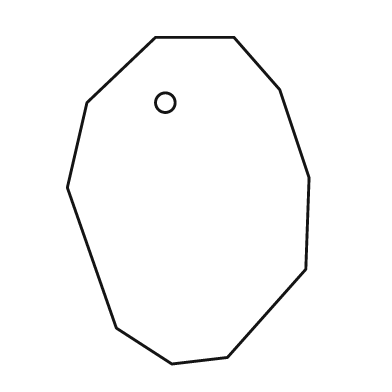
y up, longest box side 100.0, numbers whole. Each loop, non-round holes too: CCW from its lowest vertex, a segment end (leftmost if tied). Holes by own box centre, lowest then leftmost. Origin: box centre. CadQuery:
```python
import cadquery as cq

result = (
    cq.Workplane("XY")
    .moveTo(-5.0, -50.0)
    .lineTo(12.0, -48.0)
    .lineTo(36.0, -21.0)
    .lineTo(37.0, 7.0)
    .lineTo(28.0, 34.0)
    .lineTo(14.0, 50.0)
    .lineTo(-10.0, 50.0)
    .lineTo(-31.0, 30.0)
    .lineTo(-37.0, 4.0)
    .lineTo(-22.0, -39.0)
    .close()
    .moveTo(-7.0, 30.0)
    .circle(3.0)
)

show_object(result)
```